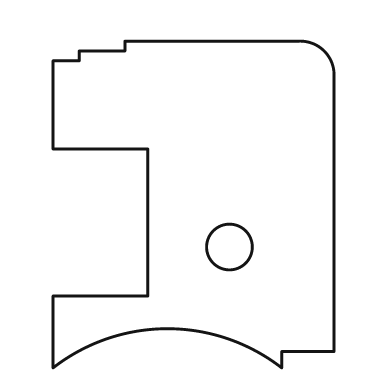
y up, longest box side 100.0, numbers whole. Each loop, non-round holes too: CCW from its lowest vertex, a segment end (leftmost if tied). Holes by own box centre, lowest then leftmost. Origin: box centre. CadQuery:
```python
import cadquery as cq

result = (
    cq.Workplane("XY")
    .moveTo(-43.0, -50.0)
    .threePointArc((-8.0, -38.0), (27.0, -50.0))
    .lineTo(27.0, -45.0)
    .lineTo(43.0, -45.0)
    .lineTo(43.0, 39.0)
    .threePointArc((40.0, 47.0), (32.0, 50.0))
    .lineTo(-21.0, 50.0)
    .lineTo(-21.0, 47.0)
    .lineTo(-35.0, 47.0)
    .lineTo(-35.0, 44.0)
    .lineTo(-43.0, 44.0)
    .lineTo(-43.0, 17.0)
    .lineTo(-14.0, 17.0)
    .lineTo(-14.0, -28.0)
    .lineTo(-43.0, -28.0)
    .close()
    .moveTo(11.0, -13.0)
    .circle(7.0)
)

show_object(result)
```